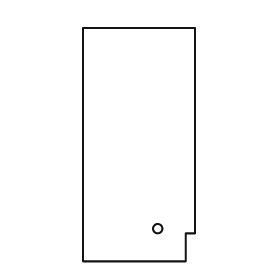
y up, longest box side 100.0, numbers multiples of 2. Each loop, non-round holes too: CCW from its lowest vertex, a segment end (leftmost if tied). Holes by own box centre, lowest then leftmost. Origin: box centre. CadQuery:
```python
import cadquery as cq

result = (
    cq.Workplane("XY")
    .moveTo(-24.0, -50.0)
    .lineTo(20.0, -50.0)
    .lineTo(20.0, -38.0)
    .lineTo(24.0, -38.0)
    .lineTo(24.0, 50.0)
    .lineTo(-24.0, 50.0)
    .close()
    .moveTo(8.0, -36.0)
    .circle(2.0)
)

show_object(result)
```